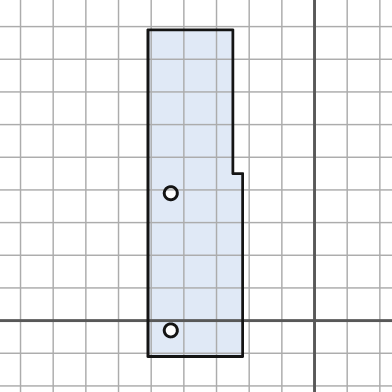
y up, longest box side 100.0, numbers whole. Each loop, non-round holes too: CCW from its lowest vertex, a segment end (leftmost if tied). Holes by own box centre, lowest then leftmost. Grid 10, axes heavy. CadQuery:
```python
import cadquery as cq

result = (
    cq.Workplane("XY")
    .moveTo(-51.0, -11.0)
    .lineTo(-22.0, -11.0)
    .lineTo(-22.0, 45.0)
    .lineTo(-25.0, 45.0)
    .lineTo(-25.0, 89.0)
    .lineTo(-51.0, 89.0)
    .close()
    .moveTo(-44.0, -3.0)
    .circle(2.0)
    .moveTo(-44.0, 39.0)
    .circle(2.0)
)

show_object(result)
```